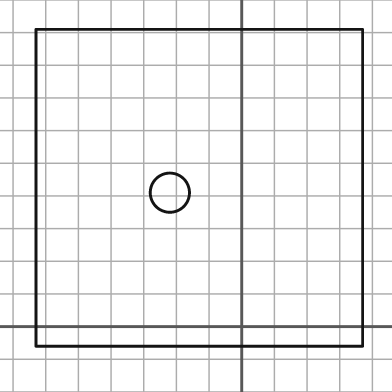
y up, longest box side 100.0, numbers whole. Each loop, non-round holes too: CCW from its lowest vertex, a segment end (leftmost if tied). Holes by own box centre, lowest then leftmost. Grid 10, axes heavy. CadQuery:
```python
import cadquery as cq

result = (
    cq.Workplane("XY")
    .moveTo(-63.0, -6.0)
    .lineTo(37.0, -6.0)
    .lineTo(37.0, 91.0)
    .lineTo(-63.0, 91.0)
    .close()
    .moveTo(-22.0, 41.0)
    .circle(6.0)
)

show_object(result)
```